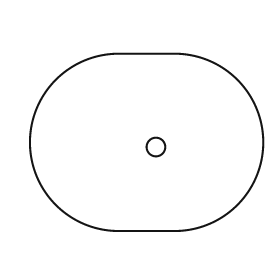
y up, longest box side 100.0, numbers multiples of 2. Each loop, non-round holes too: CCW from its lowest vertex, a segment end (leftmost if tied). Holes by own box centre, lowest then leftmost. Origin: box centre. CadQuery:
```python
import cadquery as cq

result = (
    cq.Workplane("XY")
    .moveTo(-12.0, -38.0)
    .lineTo(12.0, -38.0)
    .threePointArc((50.0, 0.0), (12.0, 38.0))
    .lineTo(-12.0, 38.0)
    .threePointArc((-50.0, 0.0), (-12.0, -38.0))
    .close()
    .moveTo(4.0, -2.0)
    .circle(4.0)
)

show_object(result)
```